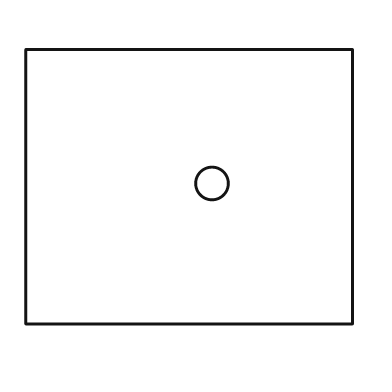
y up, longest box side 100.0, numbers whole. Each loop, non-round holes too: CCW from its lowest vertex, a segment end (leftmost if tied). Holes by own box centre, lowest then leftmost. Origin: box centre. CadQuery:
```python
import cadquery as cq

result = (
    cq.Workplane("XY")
    .moveTo(-50.0, -42.0)
    .lineTo(50.0, -42.0)
    .lineTo(50.0, 42.0)
    .lineTo(-50.0, 42.0)
    .close()
    .moveTo(7.0, 1.0)
    .circle(5.0)
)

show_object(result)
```